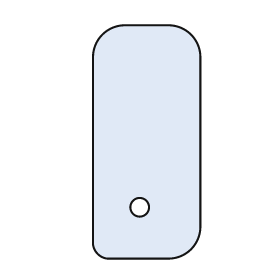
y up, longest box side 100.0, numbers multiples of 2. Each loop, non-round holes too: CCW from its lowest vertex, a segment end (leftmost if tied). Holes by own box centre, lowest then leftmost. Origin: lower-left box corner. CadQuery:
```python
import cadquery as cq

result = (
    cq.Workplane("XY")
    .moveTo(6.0, 0.0)
    .lineTo(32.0, 0.0)
    .threePointArc((42.0, 4.0), (46.0, 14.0))
    .lineTo(46.0, 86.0)
    .threePointArc((42.0, 96.0), (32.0, 100.0))
    .lineTo(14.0, 100.0)
    .threePointArc((4.0, 96.0), (0.0, 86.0))
    .lineTo(0.0, 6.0)
    .threePointArc((2.0, 2.0), (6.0, 0.0))
    .close()
    .moveTo(20.0, 22.0)
    .circle(4.0)
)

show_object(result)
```